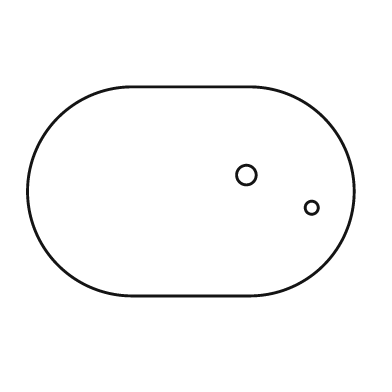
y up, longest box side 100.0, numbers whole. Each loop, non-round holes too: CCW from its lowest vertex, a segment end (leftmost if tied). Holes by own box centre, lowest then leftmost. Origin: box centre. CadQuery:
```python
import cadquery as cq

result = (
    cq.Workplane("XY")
    .moveTo(-18.0, -32.0)
    .lineTo(18.0, -32.0)
    .threePointArc((50.0, 0.0), (18.0, 32.0))
    .lineTo(-18.0, 32.0)
    .threePointArc((-50.0, 0.0), (-18.0, -32.0))
    .close()
    .moveTo(37.0, -5.0)
    .circle(2.0)
    .moveTo(17.0, 5.0)
    .circle(3.0)
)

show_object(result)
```